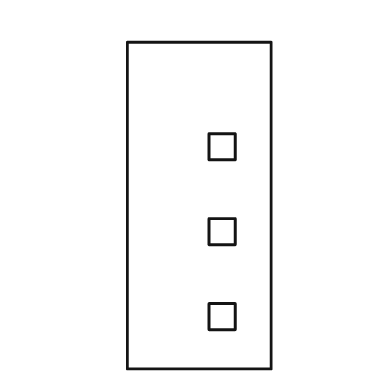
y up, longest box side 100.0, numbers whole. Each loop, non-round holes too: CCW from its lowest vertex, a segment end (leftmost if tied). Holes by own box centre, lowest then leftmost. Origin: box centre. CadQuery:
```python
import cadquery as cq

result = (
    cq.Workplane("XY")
    .moveTo(-22.0, -50.0)
    .lineTo(22.0, -50.0)
    .lineTo(22.0, 50.0)
    .lineTo(-22.0, 50.0)
    .close()
    .moveTo(3.0, -38.0)
    .lineTo(11.0, -38.0)
    .lineTo(11.0, -30.0)
    .lineTo(3.0, -30.0)
    .close()
    .moveTo(3.0, -12.0)
    .lineTo(11.0, -12.0)
    .lineTo(11.0, -4.0)
    .lineTo(3.0, -4.0)
    .close()
    .moveTo(3.0, 14.0)
    .lineTo(11.0, 14.0)
    .lineTo(11.0, 22.0)
    .lineTo(3.0, 22.0)
    .close()
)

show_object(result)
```